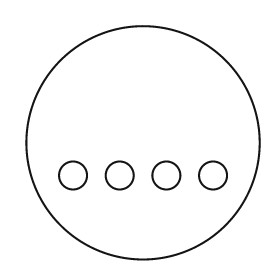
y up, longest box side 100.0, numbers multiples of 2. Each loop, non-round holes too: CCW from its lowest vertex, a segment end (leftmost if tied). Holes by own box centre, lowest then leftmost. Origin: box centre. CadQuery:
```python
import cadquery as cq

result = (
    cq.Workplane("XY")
    .moveTo(0.0, 0.0)
    .circle(50.0)
    .moveTo(-30.0, -14.0)
    .circle(6.0)
    .moveTo(-10.0, -14.0)
    .circle(6.0)
    .moveTo(10.0, -14.0)
    .circle(6.0)
    .moveTo(30.0, -14.0)
    .circle(6.0)
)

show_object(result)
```